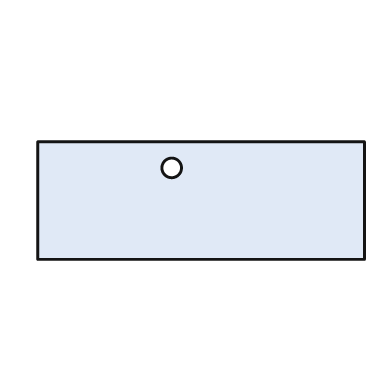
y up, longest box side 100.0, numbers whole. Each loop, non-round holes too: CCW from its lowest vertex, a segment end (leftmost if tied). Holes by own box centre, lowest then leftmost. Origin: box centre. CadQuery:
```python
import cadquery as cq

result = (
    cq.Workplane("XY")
    .moveTo(-50.0, -18.0)
    .lineTo(50.0, -18.0)
    .lineTo(50.0, 18.0)
    .lineTo(-50.0, 18.0)
    .close()
    .moveTo(-9.0, 10.0)
    .circle(3.0)
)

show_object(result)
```